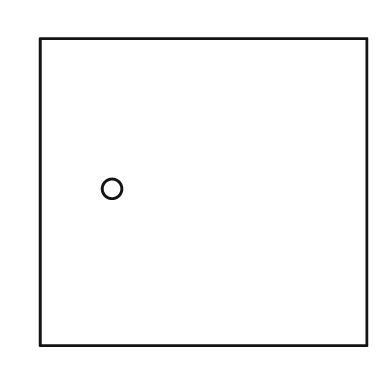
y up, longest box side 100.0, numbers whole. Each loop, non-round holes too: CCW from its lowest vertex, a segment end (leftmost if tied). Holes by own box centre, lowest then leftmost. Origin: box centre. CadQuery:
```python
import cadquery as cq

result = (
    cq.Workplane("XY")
    .moveTo(-50.0, -47.0)
    .lineTo(50.0, -47.0)
    .lineTo(50.0, 47.0)
    .lineTo(-50.0, 47.0)
    .close()
    .moveTo(-28.0, 1.0)
    .circle(3.0)
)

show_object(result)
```